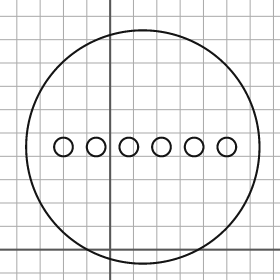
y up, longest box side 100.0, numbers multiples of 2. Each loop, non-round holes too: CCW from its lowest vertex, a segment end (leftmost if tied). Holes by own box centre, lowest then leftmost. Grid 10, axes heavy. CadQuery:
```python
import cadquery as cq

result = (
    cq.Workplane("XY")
    .moveTo(14.0, 44.0)
    .circle(50.0)
    .moveTo(-20.0, 44.0)
    .circle(4.0)
    .moveTo(-6.0, 44.0)
    .circle(4.0)
    .moveTo(8.0, 44.0)
    .circle(4.0)
    .moveTo(22.0, 44.0)
    .circle(4.0)
    .moveTo(36.0, 44.0)
    .circle(4.0)
    .moveTo(50.0, 44.0)
    .circle(4.0)
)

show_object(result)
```